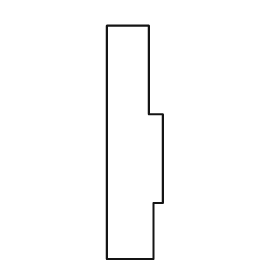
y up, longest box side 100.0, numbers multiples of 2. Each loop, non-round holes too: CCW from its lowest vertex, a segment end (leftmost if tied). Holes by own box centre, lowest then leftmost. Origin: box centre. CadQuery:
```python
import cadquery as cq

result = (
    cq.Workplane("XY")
    .moveTo(-12.0, -50.0)
    .lineTo(8.0, -50.0)
    .lineTo(8.0, -26.0)
    .lineTo(12.0, -26.0)
    .lineTo(12.0, 12.0)
    .lineTo(6.0, 12.0)
    .lineTo(6.0, 50.0)
    .lineTo(-12.0, 50.0)
    .close()
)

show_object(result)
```